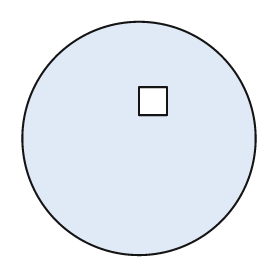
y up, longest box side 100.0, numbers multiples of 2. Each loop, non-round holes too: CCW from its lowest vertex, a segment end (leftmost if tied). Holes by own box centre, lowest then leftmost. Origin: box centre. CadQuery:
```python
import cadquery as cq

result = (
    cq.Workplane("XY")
    .moveTo(0.0, 0.0)
    .circle(50.0)
    .moveTo(0.0, 10.0)
    .lineTo(12.0, 10.0)
    .lineTo(12.0, 22.0)
    .lineTo(0.0, 22.0)
    .close()
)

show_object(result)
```